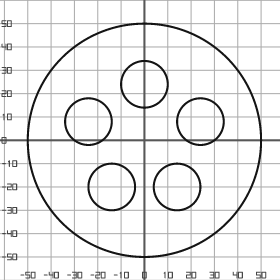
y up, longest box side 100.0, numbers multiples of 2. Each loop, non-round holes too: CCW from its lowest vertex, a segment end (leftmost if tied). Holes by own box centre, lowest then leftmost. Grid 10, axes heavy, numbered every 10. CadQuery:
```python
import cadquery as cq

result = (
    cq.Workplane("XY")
    .moveTo(0.0, 0.0)
    .circle(50.0)
    .moveTo(-14.0, -20.0)
    .circle(10.0)
    .moveTo(14.0, -20.0)
    .circle(10.0)
    .moveTo(-24.0, 8.0)
    .circle(10.0)
    .moveTo(24.0, 8.0)
    .circle(10.0)
    .moveTo(0.0, 24.0)
    .circle(10.0)
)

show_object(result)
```